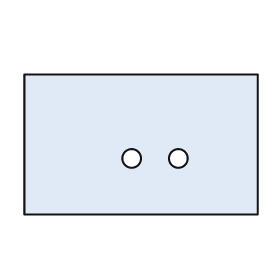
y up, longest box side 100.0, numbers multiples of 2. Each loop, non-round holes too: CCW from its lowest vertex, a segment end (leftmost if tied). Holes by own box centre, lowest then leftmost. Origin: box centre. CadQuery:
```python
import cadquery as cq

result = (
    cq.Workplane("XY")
    .moveTo(-50.0, -30.0)
    .lineTo(50.0, -30.0)
    .lineTo(50.0, 30.0)
    .lineTo(-50.0, 30.0)
    .close()
    .moveTo(-4.0, -6.0)
    .circle(4.0)
    .moveTo(16.0, -6.0)
    .circle(4.0)
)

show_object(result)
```